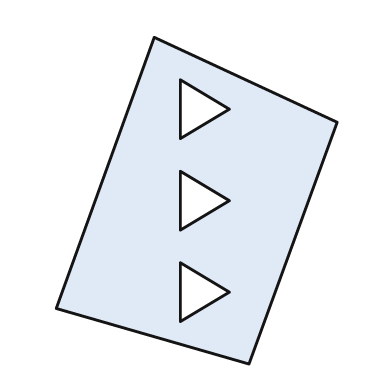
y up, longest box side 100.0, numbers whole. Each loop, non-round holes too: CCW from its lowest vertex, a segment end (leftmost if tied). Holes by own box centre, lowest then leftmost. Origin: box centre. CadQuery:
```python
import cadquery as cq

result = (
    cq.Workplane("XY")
    .moveTo(16.0, -50.0)
    .lineTo(43.0, 24.0)
    .lineTo(-13.0, 50.0)
    .lineTo(-43.0, -33.0)
    .close()
    .moveTo(-5.0, -37.0)
    .lineTo(10.0, -28.0)
    .lineTo(-5.0, -19.0)
    .close()
    .moveTo(-5.0, -9.0)
    .lineTo(10.0, 0.0)
    .lineTo(-5.0, 9.0)
    .close()
    .moveTo(-5.0, 19.0)
    .lineTo(10.0, 28.0)
    .lineTo(-5.0, 37.0)
    .close()
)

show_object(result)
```